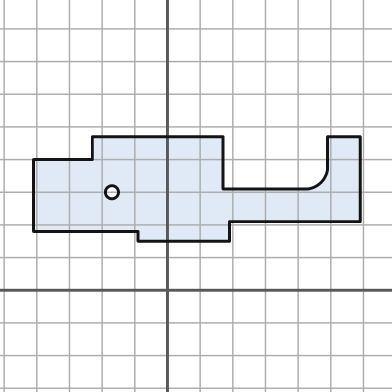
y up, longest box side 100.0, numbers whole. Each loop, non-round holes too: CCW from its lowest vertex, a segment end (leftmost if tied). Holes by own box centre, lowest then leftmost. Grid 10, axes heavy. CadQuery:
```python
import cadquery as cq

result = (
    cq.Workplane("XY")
    .moveTo(-9.0, 15.0)
    .lineTo(19.0, 15.0)
    .lineTo(19.0, 21.0)
    .lineTo(59.0, 21.0)
    .lineTo(59.0, 47.0)
    .lineTo(49.0, 47.0)
    .lineTo(49.0, 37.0)
    .threePointArc((47.0, 33.0), (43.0, 31.0))
    .lineTo(17.0, 31.0)
    .lineTo(17.0, 47.0)
    .lineTo(-23.0, 47.0)
    .lineTo(-23.0, 40.0)
    .lineTo(-41.0, 40.0)
    .lineTo(-41.0, 18.0)
    .lineTo(-9.0, 18.0)
    .close()
    .moveTo(-17.0, 30.0)
    .circle(2.0)
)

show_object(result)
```